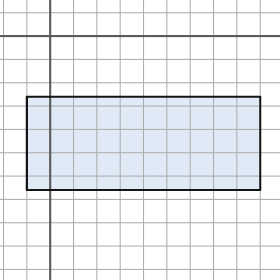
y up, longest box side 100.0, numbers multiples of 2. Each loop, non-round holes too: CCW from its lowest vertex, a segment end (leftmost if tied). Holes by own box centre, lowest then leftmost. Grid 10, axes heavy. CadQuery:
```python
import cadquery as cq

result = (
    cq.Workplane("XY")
    .moveTo(-10.0, -66.0)
    .lineTo(90.0, -66.0)
    .lineTo(90.0, -26.0)
    .lineTo(-10.0, -26.0)
    .close()
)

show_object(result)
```